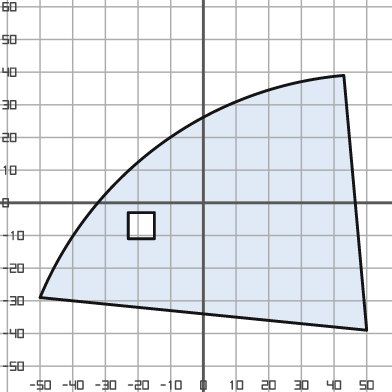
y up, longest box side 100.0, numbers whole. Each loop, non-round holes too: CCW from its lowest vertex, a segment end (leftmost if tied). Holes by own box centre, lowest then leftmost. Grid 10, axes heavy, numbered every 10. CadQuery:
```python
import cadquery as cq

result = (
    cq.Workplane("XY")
    .moveTo(50.0, -39.0)
    .lineTo(43.0, 39.0)
    .threePointArc((-13.0, 18.0), (-50.0, -29.0))
    .close()
    .moveTo(-23.0, -11.0)
    .lineTo(-15.0, -11.0)
    .lineTo(-15.0, -3.0)
    .lineTo(-23.0, -3.0)
    .close()
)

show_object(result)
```